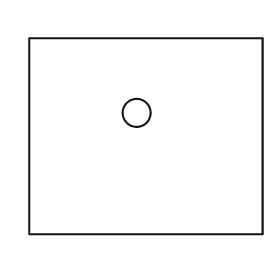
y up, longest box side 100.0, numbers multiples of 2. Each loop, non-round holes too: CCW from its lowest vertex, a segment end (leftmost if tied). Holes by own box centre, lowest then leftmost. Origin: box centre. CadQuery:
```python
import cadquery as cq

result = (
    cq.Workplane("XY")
    .moveTo(-50.0, -42.0)
    .lineTo(50.0, -42.0)
    .lineTo(50.0, 42.0)
    .lineTo(-50.0, 42.0)
    .close()
    .moveTo(-4.0, 10.0)
    .circle(6.0)
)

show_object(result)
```